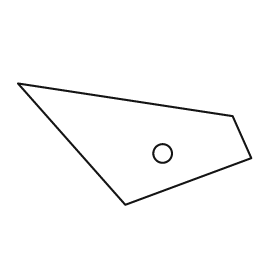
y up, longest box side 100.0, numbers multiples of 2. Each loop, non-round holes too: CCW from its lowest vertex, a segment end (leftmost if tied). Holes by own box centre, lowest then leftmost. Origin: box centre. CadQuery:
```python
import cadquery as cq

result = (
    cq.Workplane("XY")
    .moveTo(-4.0, -26.0)
    .lineTo(50.0, -6.0)
    .lineTo(42.0, 12.0)
    .lineTo(-50.0, 26.0)
    .close()
    .moveTo(12.0, -4.0)
    .circle(4.0)
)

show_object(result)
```